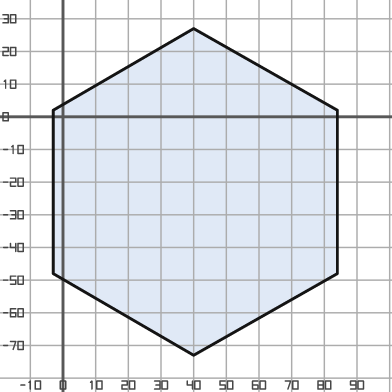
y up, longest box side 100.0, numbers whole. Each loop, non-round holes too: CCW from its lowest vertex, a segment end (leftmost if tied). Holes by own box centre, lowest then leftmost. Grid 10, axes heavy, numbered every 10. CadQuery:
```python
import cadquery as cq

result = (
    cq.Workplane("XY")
    .moveTo(40.0, -73.0)
    .lineTo(84.0, -48.0)
    .lineTo(84.0, 2.0)
    .lineTo(40.0, 27.0)
    .lineTo(-3.0, 2.0)
    .lineTo(-3.0, -48.0)
    .close()
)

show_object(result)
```